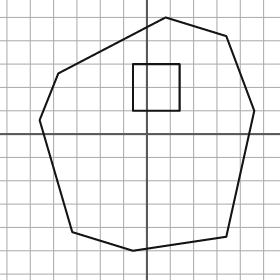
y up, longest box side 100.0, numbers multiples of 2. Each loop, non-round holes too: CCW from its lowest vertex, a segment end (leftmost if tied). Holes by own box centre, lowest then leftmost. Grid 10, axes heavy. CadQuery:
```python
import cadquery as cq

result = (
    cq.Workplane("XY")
    .moveTo(-6.0, -50.0)
    .lineTo(34.0, -44.0)
    .lineTo(46.0, 10.0)
    .lineTo(34.0, 42.0)
    .lineTo(8.0, 50.0)
    .lineTo(-38.0, 26.0)
    .lineTo(-46.0, 6.0)
    .lineTo(-32.0, -42.0)
    .close()
    .moveTo(-6.0, 10.0)
    .lineTo(14.0, 10.0)
    .lineTo(14.0, 30.0)
    .lineTo(-6.0, 30.0)
    .close()
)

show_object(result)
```